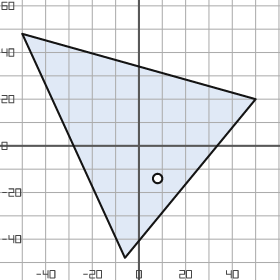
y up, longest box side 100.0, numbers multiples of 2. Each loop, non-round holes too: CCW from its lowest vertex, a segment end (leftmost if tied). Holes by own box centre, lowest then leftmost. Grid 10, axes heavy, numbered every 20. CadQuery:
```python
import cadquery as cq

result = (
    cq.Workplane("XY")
    .moveTo(-6.0, -48.0)
    .lineTo(50.0, 20.0)
    .lineTo(-50.0, 48.0)
    .close()
    .moveTo(8.0, -14.0)
    .circle(2.0)
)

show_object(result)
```